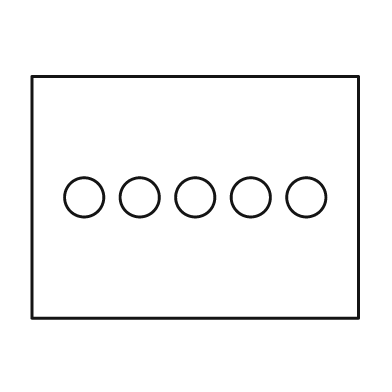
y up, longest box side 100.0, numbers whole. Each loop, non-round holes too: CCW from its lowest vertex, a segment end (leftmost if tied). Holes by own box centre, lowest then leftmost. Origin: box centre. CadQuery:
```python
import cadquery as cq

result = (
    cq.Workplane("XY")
    .moveTo(-50.0, -37.0)
    .lineTo(50.0, -37.0)
    .lineTo(50.0, 37.0)
    .lineTo(-50.0, 37.0)
    .close()
    .moveTo(-34.0, 0.0)
    .circle(6.0)
    .moveTo(-17.0, 0.0)
    .circle(6.0)
    .moveTo(0.0, 0.0)
    .circle(6.0)
    .moveTo(17.0, 0.0)
    .circle(6.0)
    .moveTo(34.0, 0.0)
    .circle(6.0)
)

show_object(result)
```